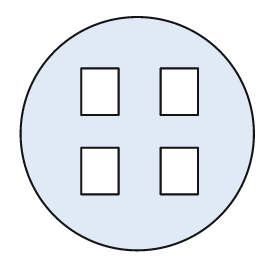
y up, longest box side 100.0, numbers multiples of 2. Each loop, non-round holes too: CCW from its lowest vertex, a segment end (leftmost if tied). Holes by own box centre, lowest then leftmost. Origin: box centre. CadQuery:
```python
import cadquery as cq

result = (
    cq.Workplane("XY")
    .moveTo(0.0, 0.0)
    .circle(50.0)
    .moveTo(-24.0, -26.0)
    .lineTo(-8.0, -26.0)
    .lineTo(-8.0, -6.0)
    .lineTo(-24.0, -6.0)
    .close()
    .moveTo(10.0, -26.0)
    .lineTo(26.0, -26.0)
    .lineTo(26.0, -6.0)
    .lineTo(10.0, -6.0)
    .close()
    .moveTo(-24.0, 8.0)
    .lineTo(-8.0, 8.0)
    .lineTo(-8.0, 28.0)
    .lineTo(-24.0, 28.0)
    .close()
    .moveTo(10.0, 8.0)
    .lineTo(26.0, 8.0)
    .lineTo(26.0, 28.0)
    .lineTo(10.0, 28.0)
    .close()
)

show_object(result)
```